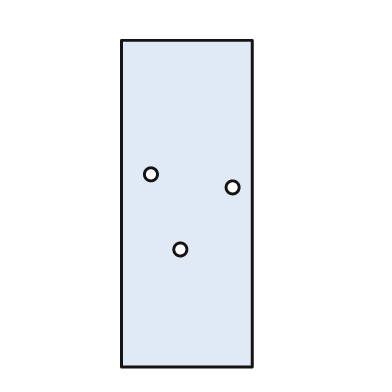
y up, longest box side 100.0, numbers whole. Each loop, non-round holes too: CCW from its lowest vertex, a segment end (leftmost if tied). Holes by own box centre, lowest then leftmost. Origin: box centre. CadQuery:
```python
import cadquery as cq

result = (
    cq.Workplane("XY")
    .moveTo(-20.0, -50.0)
    .lineTo(20.0, -50.0)
    .lineTo(20.0, 50.0)
    .lineTo(-20.0, 50.0)
    .close()
    .moveTo(-2.0, -14.0)
    .circle(2.0)
    .moveTo(14.0, 5.0)
    .circle(2.0)
    .moveTo(-11.0, 9.0)
    .circle(2.0)
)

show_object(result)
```